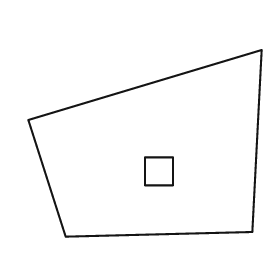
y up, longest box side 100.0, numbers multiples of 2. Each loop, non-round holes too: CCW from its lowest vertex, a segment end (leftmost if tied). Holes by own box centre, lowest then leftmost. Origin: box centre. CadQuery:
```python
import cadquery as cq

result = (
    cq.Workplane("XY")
    .moveTo(-34.0, -40.0)
    .lineTo(46.0, -38.0)
    .lineTo(50.0, 40.0)
    .lineTo(-50.0, 10.0)
    .close()
    .moveTo(0.0, -18.0)
    .lineTo(12.0, -18.0)
    .lineTo(12.0, -6.0)
    .lineTo(0.0, -6.0)
    .close()
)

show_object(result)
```